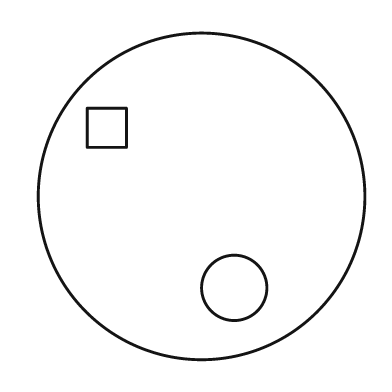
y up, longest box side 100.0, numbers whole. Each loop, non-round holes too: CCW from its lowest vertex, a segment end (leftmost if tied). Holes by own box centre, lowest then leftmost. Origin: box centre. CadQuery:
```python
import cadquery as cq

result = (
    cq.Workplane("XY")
    .moveTo(0.0, 0.0)
    .circle(50.0)
    .moveTo(10.0, -28.0)
    .circle(10.0)
    .moveTo(-35.0, 15.0)
    .lineTo(-23.0, 15.0)
    .lineTo(-23.0, 27.0)
    .lineTo(-35.0, 27.0)
    .close()
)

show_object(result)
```